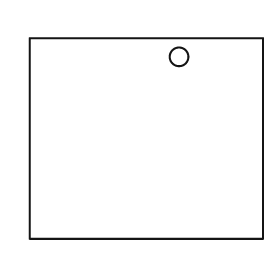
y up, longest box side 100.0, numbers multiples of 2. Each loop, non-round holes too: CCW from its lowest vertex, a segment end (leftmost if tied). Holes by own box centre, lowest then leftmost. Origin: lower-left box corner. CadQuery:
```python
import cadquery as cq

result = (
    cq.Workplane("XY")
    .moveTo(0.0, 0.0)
    .lineTo(100.0, 0.0)
    .lineTo(100.0, 86.0)
    .lineTo(0.0, 86.0)
    .close()
    .moveTo(64.0, 78.0)
    .circle(4.0)
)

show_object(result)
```